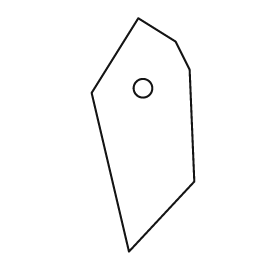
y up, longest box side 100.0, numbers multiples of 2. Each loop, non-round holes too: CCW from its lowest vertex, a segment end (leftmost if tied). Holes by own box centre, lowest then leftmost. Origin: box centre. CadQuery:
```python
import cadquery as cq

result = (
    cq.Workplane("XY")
    .moveTo(-6.0, -50.0)
    .lineTo(22.0, -20.0)
    .lineTo(20.0, 28.0)
    .lineTo(14.0, 40.0)
    .lineTo(-2.0, 50.0)
    .lineTo(-22.0, 18.0)
    .close()
    .moveTo(0.0, 20.0)
    .circle(4.0)
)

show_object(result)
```